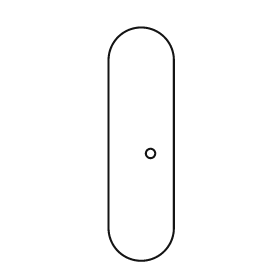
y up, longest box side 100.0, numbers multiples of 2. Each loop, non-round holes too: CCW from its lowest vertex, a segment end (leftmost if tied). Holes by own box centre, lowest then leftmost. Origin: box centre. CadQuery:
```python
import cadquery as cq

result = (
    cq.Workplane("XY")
    .moveTo(-14.0, -36.0)
    .threePointArc((0.0, -50.0), (14.0, -36.0))
    .lineTo(14.0, 36.0)
    .threePointArc((0.0, 50.0), (-14.0, 36.0))
    .close()
    .moveTo(4.0, -4.0)
    .circle(2.0)
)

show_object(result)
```